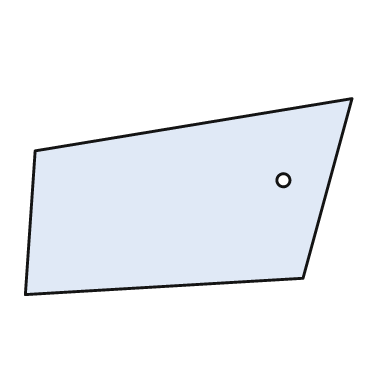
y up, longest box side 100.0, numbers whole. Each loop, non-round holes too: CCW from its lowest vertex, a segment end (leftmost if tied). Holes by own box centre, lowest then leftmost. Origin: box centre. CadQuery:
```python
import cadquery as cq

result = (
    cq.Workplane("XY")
    .moveTo(-50.0, -30.0)
    .lineTo(35.0, -25.0)
    .lineTo(50.0, 30.0)
    .lineTo(-47.0, 14.0)
    .close()
    .moveTo(29.0, 5.0)
    .circle(2.0)
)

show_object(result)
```